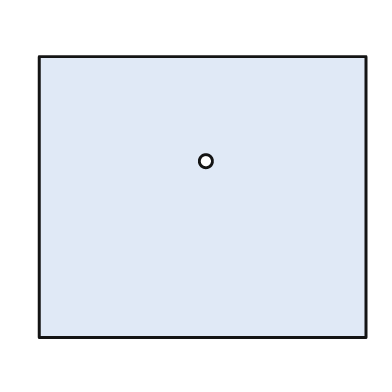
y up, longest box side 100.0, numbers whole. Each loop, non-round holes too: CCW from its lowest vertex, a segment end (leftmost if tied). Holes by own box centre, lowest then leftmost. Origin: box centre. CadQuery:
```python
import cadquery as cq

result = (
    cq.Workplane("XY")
    .moveTo(-50.0, -43.0)
    .lineTo(50.0, -43.0)
    .lineTo(50.0, 43.0)
    .lineTo(-50.0, 43.0)
    .close()
    .moveTo(1.0, 11.0)
    .circle(2.0)
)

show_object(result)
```